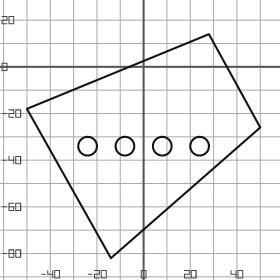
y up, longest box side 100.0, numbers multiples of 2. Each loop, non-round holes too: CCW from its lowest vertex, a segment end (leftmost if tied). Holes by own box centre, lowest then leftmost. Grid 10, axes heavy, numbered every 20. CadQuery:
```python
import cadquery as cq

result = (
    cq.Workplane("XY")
    .moveTo(-14.0, -82.0)
    .lineTo(50.0, -26.0)
    .lineTo(28.0, 14.0)
    .lineTo(-50.0, -18.0)
    .close()
    .moveTo(-24.0, -34.0)
    .circle(4.0)
    .moveTo(-8.0, -34.0)
    .circle(4.0)
    .moveTo(8.0, -34.0)
    .circle(4.0)
    .moveTo(24.0, -34.0)
    .circle(4.0)
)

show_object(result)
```